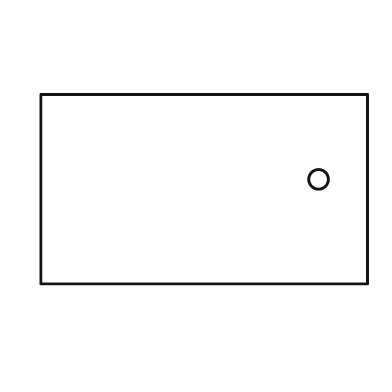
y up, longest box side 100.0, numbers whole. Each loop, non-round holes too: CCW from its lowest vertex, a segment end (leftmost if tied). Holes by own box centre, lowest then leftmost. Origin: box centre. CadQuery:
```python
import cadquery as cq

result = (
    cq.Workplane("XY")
    .moveTo(-50.0, -29.0)
    .lineTo(50.0, -29.0)
    .lineTo(50.0, 29.0)
    .lineTo(-50.0, 29.0)
    .close()
    .moveTo(35.0, 3.0)
    .circle(3.0)
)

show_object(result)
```